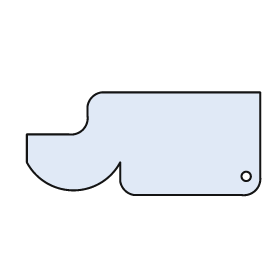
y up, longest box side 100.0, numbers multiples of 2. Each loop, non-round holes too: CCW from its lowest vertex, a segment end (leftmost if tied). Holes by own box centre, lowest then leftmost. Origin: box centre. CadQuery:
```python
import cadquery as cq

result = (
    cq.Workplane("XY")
    .moveTo(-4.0, -22.0)
    .lineTo(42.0, -22.0)
    .threePointArc((48.0, -20.0), (50.0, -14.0))
    .lineTo(50.0, 22.0)
    .lineTo(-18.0, 22.0)
    .threePointArc((-22.0, 20.0), (-24.0, 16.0))
    .lineTo(-24.0, 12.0)
    .threePointArc((-26.0, 6.0), (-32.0, 4.0))
    .lineTo(-50.0, 4.0)
    .lineTo(-50.0, -8.0)
    .threePointArc((-30.0, -20.0), (-10.0, -8.0))
    .lineTo(-10.0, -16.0)
    .threePointArc((-8.0, -20.0), (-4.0, -22.0))
    .close()
    .moveTo(44.0, -14.0)
    .circle(2.0)
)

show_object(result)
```